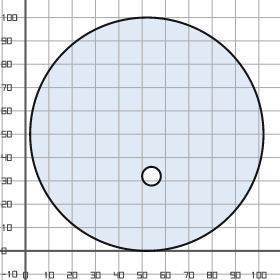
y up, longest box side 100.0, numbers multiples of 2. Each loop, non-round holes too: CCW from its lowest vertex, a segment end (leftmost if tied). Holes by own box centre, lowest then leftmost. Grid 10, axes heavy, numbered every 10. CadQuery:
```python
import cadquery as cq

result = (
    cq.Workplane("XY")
    .moveTo(52.0, 50.0)
    .circle(50.0)
    .moveTo(54.0, 32.0)
    .circle(4.0)
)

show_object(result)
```